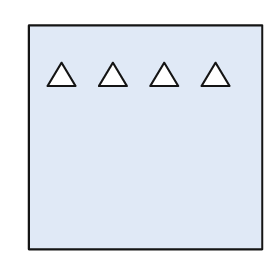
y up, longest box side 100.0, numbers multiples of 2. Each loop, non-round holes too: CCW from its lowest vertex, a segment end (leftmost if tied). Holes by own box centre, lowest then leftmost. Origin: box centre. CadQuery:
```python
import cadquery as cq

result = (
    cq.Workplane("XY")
    .moveTo(-50.0, -48.0)
    .lineTo(50.0, -48.0)
    .lineTo(50.0, 48.0)
    .lineTo(-50.0, 48.0)
    .close()
    .moveTo(-42.0, 22.0)
    .lineTo(-30.0, 22.0)
    .lineTo(-36.0, 32.0)
    .close()
    .moveTo(-20.0, 22.0)
    .lineTo(-8.0, 22.0)
    .lineTo(-14.0, 32.0)
    .close()
    .moveTo(2.0, 22.0)
    .lineTo(14.0, 22.0)
    .lineTo(8.0, 32.0)
    .close()
    .moveTo(24.0, 22.0)
    .lineTo(36.0, 22.0)
    .lineTo(30.0, 32.0)
    .close()
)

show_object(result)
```